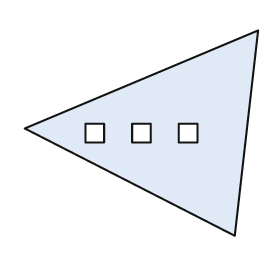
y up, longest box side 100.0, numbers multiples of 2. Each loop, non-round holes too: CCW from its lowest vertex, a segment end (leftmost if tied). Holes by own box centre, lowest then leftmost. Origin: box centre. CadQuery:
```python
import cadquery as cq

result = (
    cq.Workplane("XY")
    .moveTo(40.0, -44.0)
    .lineTo(50.0, 44.0)
    .lineTo(-50.0, 2.0)
    .close()
    .moveTo(-24.0, -4.0)
    .lineTo(-16.0, -4.0)
    .lineTo(-16.0, 4.0)
    .lineTo(-24.0, 4.0)
    .close()
    .moveTo(-4.0, -4.0)
    .lineTo(4.0, -4.0)
    .lineTo(4.0, 4.0)
    .lineTo(-4.0, 4.0)
    .close()
    .moveTo(16.0, -4.0)
    .lineTo(24.0, -4.0)
    .lineTo(24.0, 4.0)
    .lineTo(16.0, 4.0)
    .close()
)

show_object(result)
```